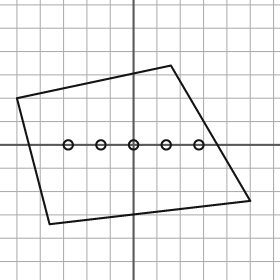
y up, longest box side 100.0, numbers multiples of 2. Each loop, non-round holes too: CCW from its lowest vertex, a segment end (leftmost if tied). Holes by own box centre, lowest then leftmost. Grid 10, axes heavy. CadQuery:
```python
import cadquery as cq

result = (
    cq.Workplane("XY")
    .moveTo(-36.0, -34.0)
    .lineTo(50.0, -24.0)
    .lineTo(16.0, 34.0)
    .lineTo(-50.0, 20.0)
    .close()
    .moveTo(-28.0, 0.0)
    .circle(2.0)
    .moveTo(-14.0, 0.0)
    .circle(2.0)
    .moveTo(0.0, 0.0)
    .circle(2.0)
    .moveTo(14.0, 0.0)
    .circle(2.0)
    .moveTo(28.0, 0.0)
    .circle(2.0)
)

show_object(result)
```